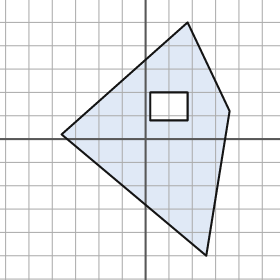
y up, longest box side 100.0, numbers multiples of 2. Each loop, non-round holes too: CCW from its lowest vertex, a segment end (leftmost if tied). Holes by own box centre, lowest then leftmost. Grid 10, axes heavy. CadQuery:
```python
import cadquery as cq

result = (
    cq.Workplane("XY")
    .moveTo(26.0, -50.0)
    .lineTo(36.0, 12.0)
    .lineTo(18.0, 50.0)
    .lineTo(-36.0, 2.0)
    .close()
    .moveTo(2.0, 8.0)
    .lineTo(18.0, 8.0)
    .lineTo(18.0, 20.0)
    .lineTo(2.0, 20.0)
    .close()
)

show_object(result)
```